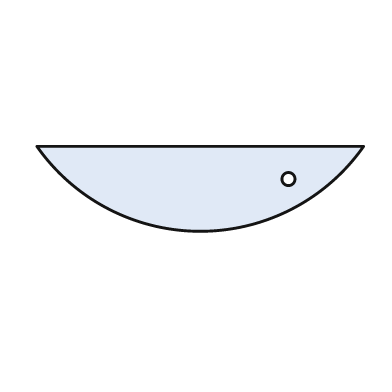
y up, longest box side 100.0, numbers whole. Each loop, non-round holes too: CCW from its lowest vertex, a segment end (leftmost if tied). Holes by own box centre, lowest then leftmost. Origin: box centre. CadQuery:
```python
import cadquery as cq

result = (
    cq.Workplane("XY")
    .moveTo(-50.0, 13.0)
    .threePointArc((0.0, -13.0), (50.0, 13.0))
    .close()
    .moveTo(27.0, 3.0)
    .circle(2.0)
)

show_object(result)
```